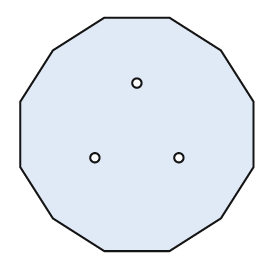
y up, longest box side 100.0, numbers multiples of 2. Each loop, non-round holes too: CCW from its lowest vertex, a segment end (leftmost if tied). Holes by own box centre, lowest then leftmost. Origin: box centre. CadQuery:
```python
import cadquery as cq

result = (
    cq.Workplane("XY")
    .moveTo(-14.0, -50.0)
    .lineTo(14.0, -50.0)
    .lineTo(36.0, -36.0)
    .lineTo(50.0, -14.0)
    .lineTo(50.0, 14.0)
    .lineTo(36.0, 36.0)
    .lineTo(14.0, 50.0)
    .lineTo(-14.0, 50.0)
    .lineTo(-36.0, 36.0)
    .lineTo(-50.0, 14.0)
    .lineTo(-50.0, -14.0)
    .lineTo(-36.0, -36.0)
    .close()
    .moveTo(-18.0, -10.0)
    .circle(2.0)
    .moveTo(18.0, -10.0)
    .circle(2.0)
    .moveTo(0.0, 22.0)
    .circle(2.0)
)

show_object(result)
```